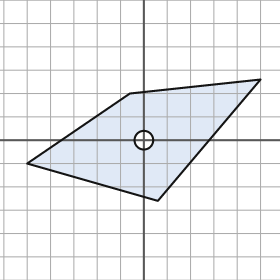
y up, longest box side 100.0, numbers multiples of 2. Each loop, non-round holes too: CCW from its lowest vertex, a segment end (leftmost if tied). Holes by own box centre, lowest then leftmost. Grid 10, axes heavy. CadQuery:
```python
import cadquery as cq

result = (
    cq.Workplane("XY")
    .moveTo(6.0, -26.0)
    .lineTo(50.0, 26.0)
    .lineTo(-6.0, 20.0)
    .lineTo(-50.0, -10.0)
    .close()
    .moveTo(0.0, 0.0)
    .circle(4.0)
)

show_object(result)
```